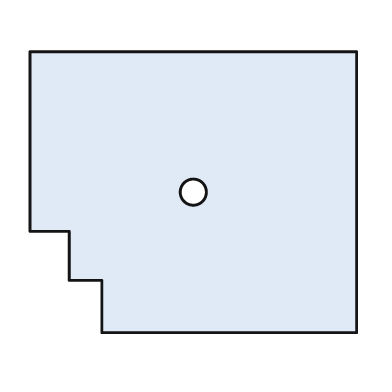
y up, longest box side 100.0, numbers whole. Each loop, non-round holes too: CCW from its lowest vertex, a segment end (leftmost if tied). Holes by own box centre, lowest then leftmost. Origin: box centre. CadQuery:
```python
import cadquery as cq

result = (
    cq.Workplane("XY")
    .moveTo(-28.0, -43.0)
    .lineTo(50.0, -43.0)
    .lineTo(50.0, 43.0)
    .lineTo(-50.0, 43.0)
    .lineTo(-50.0, -12.0)
    .lineTo(-38.0, -12.0)
    .lineTo(-38.0, -27.0)
    .lineTo(-28.0, -27.0)
    .close()
    .moveTo(0.0, 0.0)
    .circle(4.0)
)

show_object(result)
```